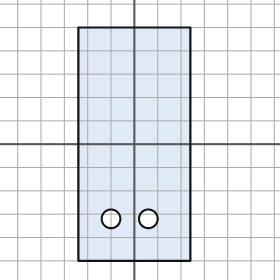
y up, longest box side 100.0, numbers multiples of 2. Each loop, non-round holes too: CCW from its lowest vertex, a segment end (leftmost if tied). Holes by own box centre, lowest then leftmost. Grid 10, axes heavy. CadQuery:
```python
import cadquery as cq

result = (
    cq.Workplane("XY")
    .moveTo(-24.0, -50.0)
    .lineTo(24.0, -50.0)
    .lineTo(24.0, 50.0)
    .lineTo(-24.0, 50.0)
    .close()
    .moveTo(-10.0, -32.0)
    .circle(4.0)
    .moveTo(6.0, -32.0)
    .circle(4.0)
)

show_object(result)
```